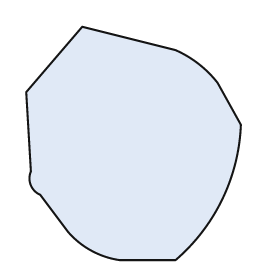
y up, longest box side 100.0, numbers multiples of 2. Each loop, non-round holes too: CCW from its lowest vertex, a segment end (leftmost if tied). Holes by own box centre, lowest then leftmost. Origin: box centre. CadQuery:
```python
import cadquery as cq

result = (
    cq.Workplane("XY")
    .moveTo(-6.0, -50.0)
    .lineTo(18.0, -50.0)
    .threePointArc((38.0, -24.0), (46.0, 8.0))
    .lineTo(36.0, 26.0)
    .threePointArc((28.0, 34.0), (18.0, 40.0))
    .lineTo(-22.0, 50.0)
    .lineTo(-46.0, 22.0)
    .lineTo(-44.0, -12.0)
    .threePointArc((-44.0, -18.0), (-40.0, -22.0))
    .lineTo(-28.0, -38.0)
    .threePointArc((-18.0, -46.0), (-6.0, -50.0))
    .close()
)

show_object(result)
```